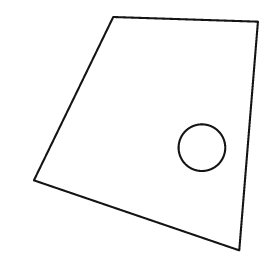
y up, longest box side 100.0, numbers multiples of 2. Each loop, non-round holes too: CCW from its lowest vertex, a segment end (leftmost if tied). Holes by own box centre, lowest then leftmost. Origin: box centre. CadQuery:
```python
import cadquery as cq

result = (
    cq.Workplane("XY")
    .moveTo(40.0, -50.0)
    .lineTo(48.0, 48.0)
    .lineTo(-14.0, 50.0)
    .lineTo(-48.0, -20.0)
    .close()
    .moveTo(24.0, -6.0)
    .circle(10.0)
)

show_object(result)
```